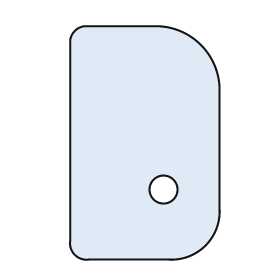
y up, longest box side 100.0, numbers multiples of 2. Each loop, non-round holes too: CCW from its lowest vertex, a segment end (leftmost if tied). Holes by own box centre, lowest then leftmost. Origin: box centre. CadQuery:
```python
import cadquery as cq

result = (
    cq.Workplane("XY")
    .moveTo(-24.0, -50.0)
    .lineTo(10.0, -50.0)
    .threePointArc((26.0, -44.0), (32.0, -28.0))
    .lineTo(32.0, 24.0)
    .threePointArc((24.0, 42.0), (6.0, 50.0))
    .lineTo(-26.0, 50.0)
    .threePointArc((-30.0, 48.0), (-32.0, 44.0))
    .lineTo(-32.0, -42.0)
    .threePointArc((-30.0, -48.0), (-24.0, -50.0))
    .close()
    .moveTo(8.0, -20.0)
    .circle(6.0)
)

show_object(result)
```